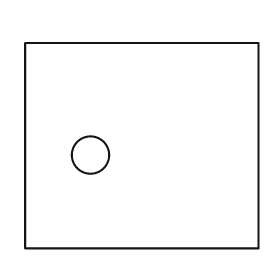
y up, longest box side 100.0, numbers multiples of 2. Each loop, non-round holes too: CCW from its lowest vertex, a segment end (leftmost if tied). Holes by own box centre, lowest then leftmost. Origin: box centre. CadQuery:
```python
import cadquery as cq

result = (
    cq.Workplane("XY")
    .moveTo(-50.0, -44.0)
    .lineTo(50.0, -44.0)
    .lineTo(50.0, 44.0)
    .lineTo(-50.0, 44.0)
    .close()
    .moveTo(-22.0, -4.0)
    .circle(8.0)
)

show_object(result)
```